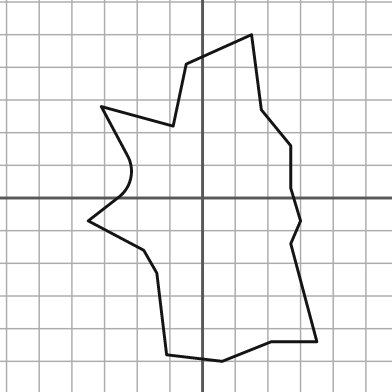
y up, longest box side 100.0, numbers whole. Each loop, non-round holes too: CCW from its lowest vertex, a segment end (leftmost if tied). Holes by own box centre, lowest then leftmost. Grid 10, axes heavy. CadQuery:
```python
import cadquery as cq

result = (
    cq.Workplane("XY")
    .moveTo(6.0, -50.0)
    .lineTo(21.0, -44.0)
    .lineTo(35.0, -44.0)
    .lineTo(27.0, -14.0)
    .lineTo(30.0, -7.0)
    .lineTo(27.0, 3.0)
    .lineTo(27.0, 16.0)
    .lineTo(18.0, 27.0)
    .lineTo(15.0, 50.0)
    .lineTo(-5.0, 41.0)
    .lineTo(-9.0, 22.0)
    .lineTo(-31.0, 28.0)
    .lineTo(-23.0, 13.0)
    .threePointArc((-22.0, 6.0), (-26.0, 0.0))
    .lineTo(-35.0, -7.0)
    .lineTo(-18.0, -16.0)
    .lineTo(-14.0, -23.0)
    .lineTo(-11.0, -48.0)
    .close()
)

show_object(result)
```